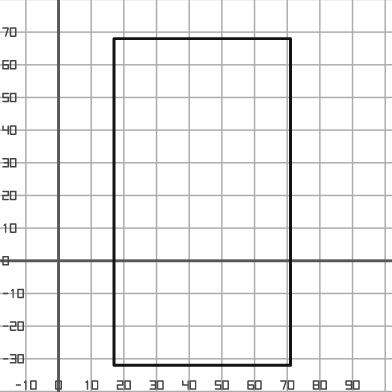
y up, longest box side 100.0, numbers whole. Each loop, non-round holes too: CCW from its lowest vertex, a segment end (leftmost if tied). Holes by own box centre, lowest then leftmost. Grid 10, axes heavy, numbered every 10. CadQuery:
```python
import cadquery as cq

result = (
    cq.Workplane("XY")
    .moveTo(17.0, -32.0)
    .lineTo(71.0, -32.0)
    .lineTo(71.0, 68.0)
    .lineTo(17.0, 68.0)
    .close()
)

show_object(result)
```